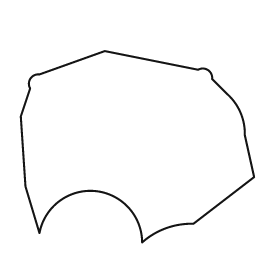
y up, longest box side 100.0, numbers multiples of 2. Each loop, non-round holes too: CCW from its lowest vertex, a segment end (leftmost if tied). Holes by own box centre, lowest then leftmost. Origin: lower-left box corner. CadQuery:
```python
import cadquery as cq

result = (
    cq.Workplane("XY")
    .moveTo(52.0, 0.0)
    .threePointArc((62.0, 6.0), (74.0, 8.0))
    .lineTo(100.0, 28.0)
    .lineTo(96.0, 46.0)
    .threePointArc((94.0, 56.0), (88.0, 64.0))
    .lineTo(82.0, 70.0)
    .threePointArc((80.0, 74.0), (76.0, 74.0))
    .lineTo(36.0, 82.0)
    .lineTo(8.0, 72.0)
    .threePointArc((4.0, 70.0), (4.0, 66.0))
    .lineTo(0.0, 54.0)
    .lineTo(2.0, 24.0)
    .lineTo(8.0, 4.0)
    .threePointArc((32.0, 22.0), (52.0, 0.0))
    .close()
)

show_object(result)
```